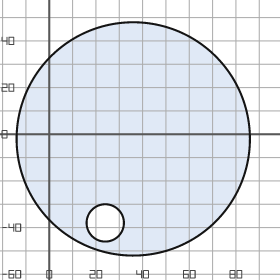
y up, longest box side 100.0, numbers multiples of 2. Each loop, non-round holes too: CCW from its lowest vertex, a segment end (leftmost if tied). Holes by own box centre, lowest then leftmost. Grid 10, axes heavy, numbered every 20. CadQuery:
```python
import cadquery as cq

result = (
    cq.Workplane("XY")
    .moveTo(36.0, -2.0)
    .circle(50.0)
    .moveTo(24.0, -38.0)
    .circle(8.0)
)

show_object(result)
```